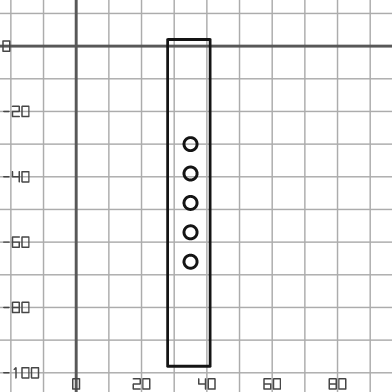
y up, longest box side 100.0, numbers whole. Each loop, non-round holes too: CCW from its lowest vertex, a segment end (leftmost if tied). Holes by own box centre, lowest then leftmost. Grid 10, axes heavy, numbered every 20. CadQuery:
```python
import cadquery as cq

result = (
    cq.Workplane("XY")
    .moveTo(28.0, -98.0)
    .lineTo(41.0, -98.0)
    .lineTo(41.0, 2.0)
    .lineTo(28.0, 2.0)
    .close()
    .moveTo(35.0, -66.0)
    .circle(2.0)
    .moveTo(35.0, -57.0)
    .circle(2.0)
    .moveTo(35.0, -48.0)
    .circle(2.0)
    .moveTo(35.0, -39.0)
    .circle(2.0)
    .moveTo(35.0, -30.0)
    .circle(2.0)
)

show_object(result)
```